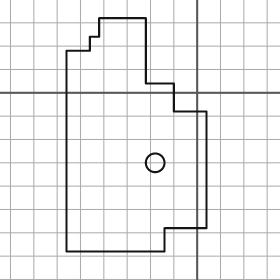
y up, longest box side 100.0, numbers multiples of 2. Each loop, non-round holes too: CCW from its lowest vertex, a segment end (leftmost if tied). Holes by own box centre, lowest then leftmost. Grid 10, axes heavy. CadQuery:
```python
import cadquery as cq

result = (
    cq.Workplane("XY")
    .moveTo(-56.0, -68.0)
    .lineTo(-14.0, -68.0)
    .lineTo(-14.0, -58.0)
    .lineTo(4.0, -58.0)
    .lineTo(4.0, -8.0)
    .lineTo(-10.0, -8.0)
    .lineTo(-10.0, 4.0)
    .lineTo(-22.0, 4.0)
    .lineTo(-22.0, 32.0)
    .lineTo(-42.0, 32.0)
    .lineTo(-42.0, 24.0)
    .lineTo(-46.0, 24.0)
    .lineTo(-46.0, 18.0)
    .lineTo(-56.0, 18.0)
    .close()
    .moveTo(-18.0, -30.0)
    .circle(4.0)
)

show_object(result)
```